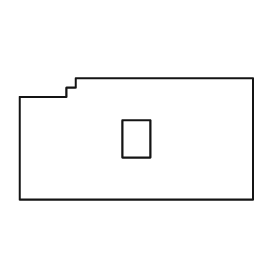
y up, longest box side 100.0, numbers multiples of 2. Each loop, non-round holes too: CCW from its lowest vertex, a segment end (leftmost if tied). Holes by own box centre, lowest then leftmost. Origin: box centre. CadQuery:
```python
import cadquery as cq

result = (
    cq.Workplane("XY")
    .moveTo(-50.0, -26.0)
    .lineTo(50.0, -26.0)
    .lineTo(50.0, 26.0)
    .lineTo(-26.0, 26.0)
    .lineTo(-26.0, 22.0)
    .lineTo(-30.0, 22.0)
    .lineTo(-30.0, 18.0)
    .lineTo(-50.0, 18.0)
    .close()
    .moveTo(-6.0, -8.0)
    .lineTo(6.0, -8.0)
    .lineTo(6.0, 8.0)
    .lineTo(-6.0, 8.0)
    .close()
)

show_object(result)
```